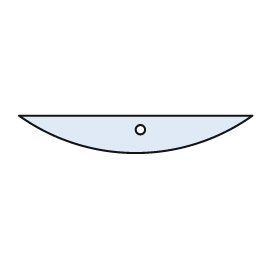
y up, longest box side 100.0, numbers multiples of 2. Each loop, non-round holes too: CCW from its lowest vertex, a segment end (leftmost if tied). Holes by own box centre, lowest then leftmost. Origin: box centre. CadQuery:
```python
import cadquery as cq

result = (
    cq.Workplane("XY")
    .moveTo(-50.0, 8.0)
    .threePointArc((0.0, -8.0), (50.0, 8.0))
    .close()
    .moveTo(2.0, 2.0)
    .circle(2.0)
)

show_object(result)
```